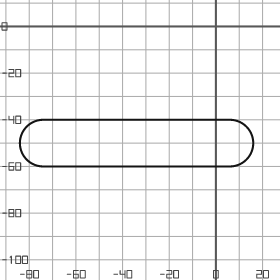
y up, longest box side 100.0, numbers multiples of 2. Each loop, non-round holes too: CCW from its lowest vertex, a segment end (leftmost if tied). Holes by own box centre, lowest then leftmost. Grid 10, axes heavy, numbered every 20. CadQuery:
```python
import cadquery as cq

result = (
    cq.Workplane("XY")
    .moveTo(-74.0, -60.0)
    .lineTo(6.0, -60.0)
    .threePointArc((16.0, -50.0), (6.0, -40.0))
    .lineTo(-74.0, -40.0)
    .threePointArc((-84.0, -50.0), (-74.0, -60.0))
    .close()
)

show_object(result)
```